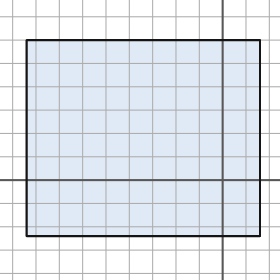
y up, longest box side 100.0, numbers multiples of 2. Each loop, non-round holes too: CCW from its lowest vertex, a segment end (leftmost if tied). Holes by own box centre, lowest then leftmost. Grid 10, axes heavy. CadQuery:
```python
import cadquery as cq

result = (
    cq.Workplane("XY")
    .moveTo(-84.0, -24.0)
    .lineTo(16.0, -24.0)
    .lineTo(16.0, 60.0)
    .lineTo(-84.0, 60.0)
    .close()
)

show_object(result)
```